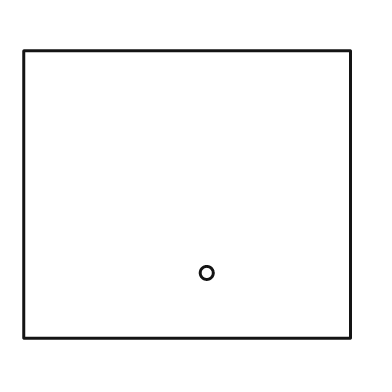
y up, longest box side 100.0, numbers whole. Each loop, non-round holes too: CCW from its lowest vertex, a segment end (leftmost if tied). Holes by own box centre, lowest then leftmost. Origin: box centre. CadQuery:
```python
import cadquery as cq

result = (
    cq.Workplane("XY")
    .moveTo(-50.0, -44.0)
    .lineTo(50.0, -44.0)
    .lineTo(50.0, 44.0)
    .lineTo(-50.0, 44.0)
    .close()
    .moveTo(6.0, -24.0)
    .circle(2.0)
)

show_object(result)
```